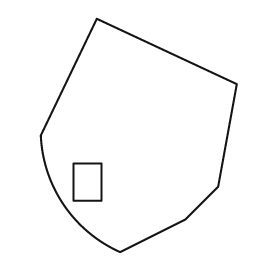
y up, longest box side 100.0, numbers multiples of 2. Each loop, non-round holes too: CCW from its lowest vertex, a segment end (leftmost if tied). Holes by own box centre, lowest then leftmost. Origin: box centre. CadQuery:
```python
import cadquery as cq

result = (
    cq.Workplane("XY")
    .moveTo(-8.0, -50.0)
    .lineTo(20.0, -36.0)
    .lineTo(34.0, -22.0)
    .lineTo(42.0, 22.0)
    .lineTo(-18.0, 50.0)
    .lineTo(-42.0, 0.0)
    .threePointArc((-32.0, -30.0), (-8.0, -50.0))
    .close()
    .moveTo(-28.0, -28.0)
    .lineTo(-16.0, -28.0)
    .lineTo(-16.0, -12.0)
    .lineTo(-28.0, -12.0)
    .close()
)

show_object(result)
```